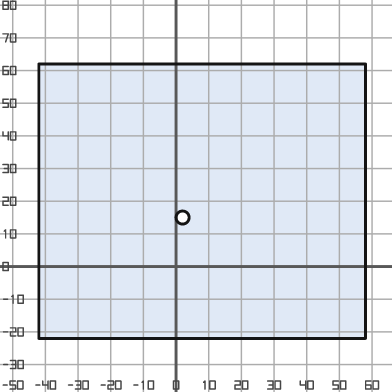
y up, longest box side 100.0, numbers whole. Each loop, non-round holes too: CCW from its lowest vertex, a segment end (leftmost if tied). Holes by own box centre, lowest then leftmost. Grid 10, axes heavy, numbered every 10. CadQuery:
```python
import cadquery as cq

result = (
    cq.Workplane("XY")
    .moveTo(-42.0, -22.0)
    .lineTo(58.0, -22.0)
    .lineTo(58.0, 62.0)
    .lineTo(-42.0, 62.0)
    .close()
    .moveTo(2.0, 15.0)
    .circle(2.0)
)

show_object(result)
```